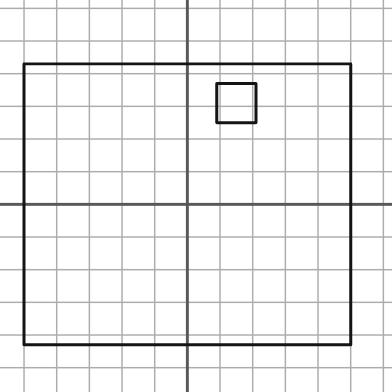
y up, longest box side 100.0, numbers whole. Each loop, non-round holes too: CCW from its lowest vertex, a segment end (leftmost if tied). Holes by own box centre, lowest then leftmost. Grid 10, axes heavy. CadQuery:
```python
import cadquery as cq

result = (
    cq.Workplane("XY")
    .moveTo(-50.0, -43.0)
    .lineTo(50.0, -43.0)
    .lineTo(50.0, 43.0)
    .lineTo(-50.0, 43.0)
    .close()
    .moveTo(9.0, 25.0)
    .lineTo(21.0, 25.0)
    .lineTo(21.0, 37.0)
    .lineTo(9.0, 37.0)
    .close()
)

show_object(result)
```